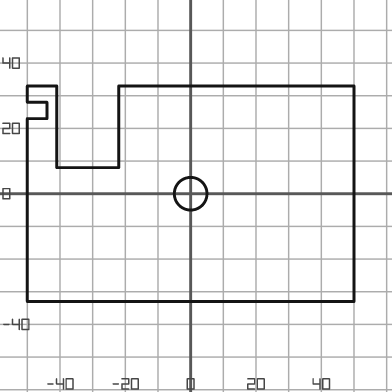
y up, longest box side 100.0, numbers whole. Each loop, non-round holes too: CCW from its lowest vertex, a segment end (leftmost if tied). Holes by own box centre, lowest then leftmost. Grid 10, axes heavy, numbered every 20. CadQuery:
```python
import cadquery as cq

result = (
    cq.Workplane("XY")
    .moveTo(-50.0, -33.0)
    .lineTo(50.0, -33.0)
    .lineTo(50.0, 33.0)
    .lineTo(-22.0, 33.0)
    .lineTo(-22.0, 8.0)
    .lineTo(-41.0, 8.0)
    .lineTo(-41.0, 33.0)
    .lineTo(-50.0, 33.0)
    .lineTo(-50.0, 28.0)
    .lineTo(-44.0, 28.0)
    .lineTo(-44.0, 23.0)
    .lineTo(-50.0, 23.0)
    .close()
    .moveTo(0.0, 0.0)
    .circle(5.0)
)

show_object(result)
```